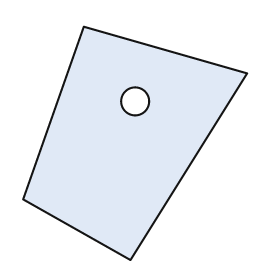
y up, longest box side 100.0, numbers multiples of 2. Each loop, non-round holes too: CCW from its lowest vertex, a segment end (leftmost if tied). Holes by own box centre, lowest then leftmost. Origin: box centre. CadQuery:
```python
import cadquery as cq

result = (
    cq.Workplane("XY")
    .moveTo(-2.0, -50.0)
    .lineTo(48.0, 30.0)
    .lineTo(-22.0, 50.0)
    .lineTo(-48.0, -24.0)
    .close()
    .moveTo(0.0, 18.0)
    .circle(6.0)
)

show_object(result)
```